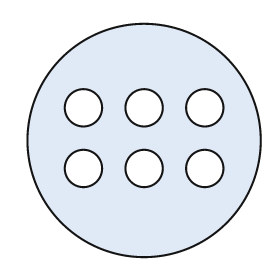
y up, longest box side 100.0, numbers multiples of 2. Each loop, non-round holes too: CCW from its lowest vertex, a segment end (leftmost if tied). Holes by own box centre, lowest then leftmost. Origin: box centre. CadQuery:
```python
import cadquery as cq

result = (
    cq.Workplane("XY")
    .moveTo(0.0, 0.0)
    .circle(50.0)
    .moveTo(-26.0, -12.0)
    .circle(8.0)
    .moveTo(0.0, -12.0)
    .circle(8.0)
    .moveTo(26.0, -12.0)
    .circle(8.0)
    .moveTo(-26.0, 14.0)
    .circle(8.0)
    .moveTo(0.0, 14.0)
    .circle(8.0)
    .moveTo(26.0, 14.0)
    .circle(8.0)
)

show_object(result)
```